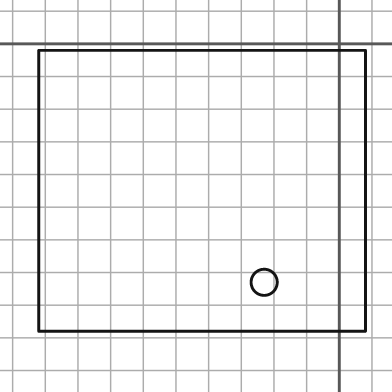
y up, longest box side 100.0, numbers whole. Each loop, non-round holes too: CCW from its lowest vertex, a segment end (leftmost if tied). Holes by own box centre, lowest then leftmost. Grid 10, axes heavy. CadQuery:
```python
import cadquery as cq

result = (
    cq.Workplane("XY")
    .moveTo(-92.0, -88.0)
    .lineTo(8.0, -88.0)
    .lineTo(8.0, -2.0)
    .lineTo(-92.0, -2.0)
    .close()
    .moveTo(-23.0, -73.0)
    .circle(4.0)
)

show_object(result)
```